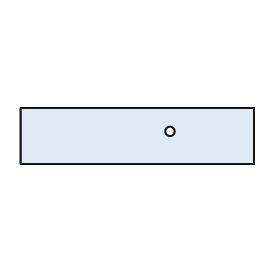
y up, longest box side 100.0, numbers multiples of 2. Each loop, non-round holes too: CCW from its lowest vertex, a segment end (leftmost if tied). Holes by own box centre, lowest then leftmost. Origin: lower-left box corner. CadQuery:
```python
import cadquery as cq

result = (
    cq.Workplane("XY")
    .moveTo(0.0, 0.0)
    .lineTo(100.0, 0.0)
    .lineTo(100.0, 24.0)
    .lineTo(0.0, 24.0)
    .close()
    .moveTo(64.0, 14.0)
    .circle(2.0)
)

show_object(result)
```